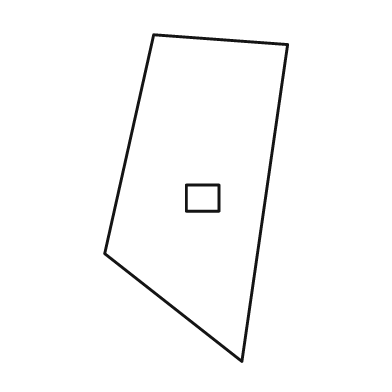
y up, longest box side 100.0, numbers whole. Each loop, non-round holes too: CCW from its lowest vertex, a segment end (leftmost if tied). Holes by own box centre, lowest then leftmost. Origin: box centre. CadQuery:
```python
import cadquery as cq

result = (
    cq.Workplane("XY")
    .moveTo(14.0, -50.0)
    .lineTo(28.0, 47.0)
    .lineTo(-13.0, 50.0)
    .lineTo(-28.0, -17.0)
    .close()
    .moveTo(-3.0, -4.0)
    .lineTo(7.0, -4.0)
    .lineTo(7.0, 4.0)
    .lineTo(-3.0, 4.0)
    .close()
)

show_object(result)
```